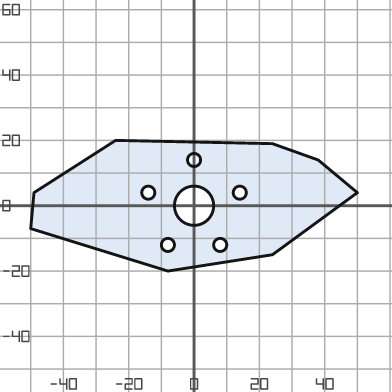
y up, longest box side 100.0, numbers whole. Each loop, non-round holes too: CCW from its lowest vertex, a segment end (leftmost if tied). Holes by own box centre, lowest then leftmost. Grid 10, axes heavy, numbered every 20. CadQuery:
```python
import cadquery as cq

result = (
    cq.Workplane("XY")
    .moveTo(-8.0, -20.0)
    .lineTo(24.0, -15.0)
    .lineTo(50.0, 4.0)
    .lineTo(38.0, 14.0)
    .lineTo(24.0, 19.0)
    .lineTo(-24.0, 20.0)
    .lineTo(-49.0, 4.0)
    .lineTo(-50.0, -7.0)
    .close()
    .moveTo(-8.0, -12.0)
    .circle(2.0)
    .moveTo(8.0, -12.0)
    .circle(2.0)
    .moveTo(0.0, 0.0)
    .circle(6.0)
    .moveTo(-14.0, 4.0)
    .circle(2.0)
    .moveTo(14.0, 4.0)
    .circle(2.0)
    .moveTo(0.0, 14.0)
    .circle(2.0)
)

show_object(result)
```